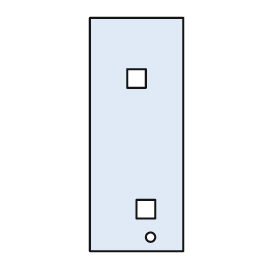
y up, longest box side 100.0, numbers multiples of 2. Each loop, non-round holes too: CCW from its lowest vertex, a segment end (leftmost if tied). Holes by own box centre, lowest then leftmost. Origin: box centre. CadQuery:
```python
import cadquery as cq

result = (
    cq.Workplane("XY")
    .moveTo(-20.0, -50.0)
    .lineTo(20.0, -50.0)
    .lineTo(20.0, 50.0)
    .lineTo(-20.0, 50.0)
    .close()
    .moveTo(6.0, -44.0)
    .circle(2.0)
    .moveTo(0.0, -36.0)
    .lineTo(8.0, -36.0)
    .lineTo(8.0, -28.0)
    .lineTo(0.0, -28.0)
    .close()
    .moveTo(-4.0, 20.0)
    .lineTo(4.0, 20.0)
    .lineTo(4.0, 28.0)
    .lineTo(-4.0, 28.0)
    .close()
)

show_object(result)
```